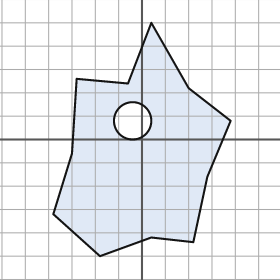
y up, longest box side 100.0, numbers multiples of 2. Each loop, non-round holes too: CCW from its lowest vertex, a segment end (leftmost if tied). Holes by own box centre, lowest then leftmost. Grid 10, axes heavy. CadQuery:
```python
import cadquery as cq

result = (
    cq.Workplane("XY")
    .moveTo(-18.0, -50.0)
    .lineTo(4.0, -42.0)
    .lineTo(22.0, -44.0)
    .lineTo(28.0, -16.0)
    .lineTo(38.0, 8.0)
    .lineTo(20.0, 22.0)
    .lineTo(4.0, 50.0)
    .lineTo(-6.0, 24.0)
    .lineTo(-28.0, 26.0)
    .lineTo(-30.0, -6.0)
    .lineTo(-38.0, -32.0)
    .close()
    .moveTo(-4.0, 8.0)
    .circle(8.0)
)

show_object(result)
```